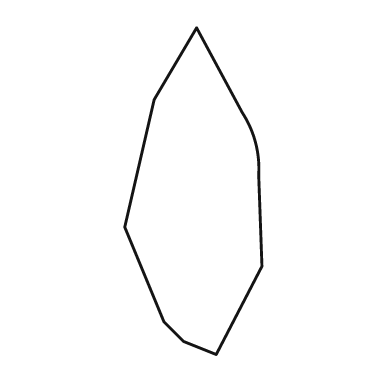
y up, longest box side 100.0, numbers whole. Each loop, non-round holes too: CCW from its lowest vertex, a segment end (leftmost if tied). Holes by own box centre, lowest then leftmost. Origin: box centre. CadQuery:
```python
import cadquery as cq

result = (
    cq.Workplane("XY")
    .moveTo(7.0, -50.0)
    .lineTo(21.0, -23.0)
    .lineTo(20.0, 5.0)
    .threePointArc((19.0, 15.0), (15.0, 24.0))
    .lineTo(1.0, 50.0)
    .lineTo(-12.0, 28.0)
    .lineTo(-21.0, -11.0)
    .lineTo(-9.0, -40.0)
    .lineTo(-3.0, -46.0)
    .close()
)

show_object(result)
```